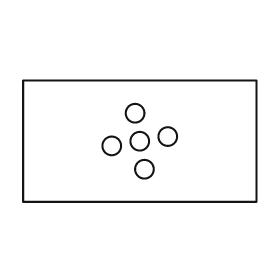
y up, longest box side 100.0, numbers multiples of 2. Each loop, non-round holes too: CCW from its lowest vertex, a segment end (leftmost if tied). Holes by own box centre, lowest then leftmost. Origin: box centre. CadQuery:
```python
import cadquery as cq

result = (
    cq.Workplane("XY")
    .moveTo(-50.0, -26.0)
    .lineTo(50.0, -26.0)
    .lineTo(50.0, 26.0)
    .lineTo(-50.0, 26.0)
    .close()
    .moveTo(2.0, -12.0)
    .circle(4.0)
    .moveTo(-12.0, -2.0)
    .circle(4.0)
    .moveTo(0.0, 0.0)
    .circle(4.0)
    .moveTo(12.0, 2.0)
    .circle(4.0)
    .moveTo(-2.0, 12.0)
    .circle(4.0)
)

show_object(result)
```